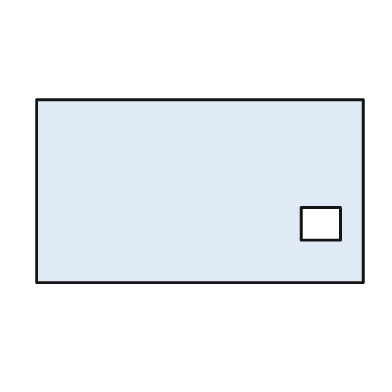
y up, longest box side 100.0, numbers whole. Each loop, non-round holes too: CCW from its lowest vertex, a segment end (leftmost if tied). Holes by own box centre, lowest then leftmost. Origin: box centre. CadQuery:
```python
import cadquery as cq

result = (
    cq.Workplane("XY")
    .moveTo(-50.0, -28.0)
    .lineTo(50.0, -28.0)
    .lineTo(50.0, 28.0)
    .lineTo(-50.0, 28.0)
    .close()
    .moveTo(31.0, -15.0)
    .lineTo(43.0, -15.0)
    .lineTo(43.0, -5.0)
    .lineTo(31.0, -5.0)
    .close()
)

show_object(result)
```